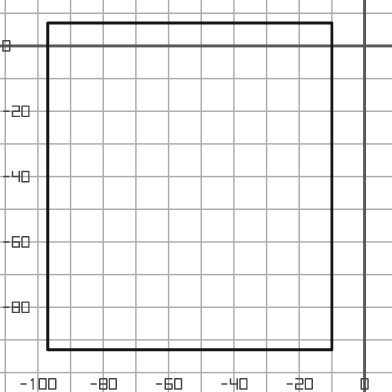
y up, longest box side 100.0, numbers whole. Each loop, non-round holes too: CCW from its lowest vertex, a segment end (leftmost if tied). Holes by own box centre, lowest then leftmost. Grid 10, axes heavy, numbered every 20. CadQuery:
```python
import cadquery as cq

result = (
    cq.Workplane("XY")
    .moveTo(-97.0, -93.0)
    .lineTo(-10.0, -93.0)
    .lineTo(-10.0, 7.0)
    .lineTo(-97.0, 7.0)
    .close()
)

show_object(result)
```